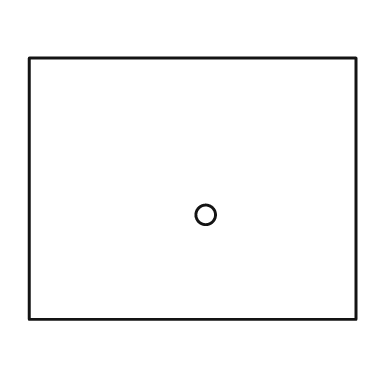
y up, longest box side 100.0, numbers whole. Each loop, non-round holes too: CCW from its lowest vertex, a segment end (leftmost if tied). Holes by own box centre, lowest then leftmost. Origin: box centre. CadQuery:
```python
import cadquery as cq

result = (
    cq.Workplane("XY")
    .moveTo(-50.0, -40.0)
    .lineTo(50.0, -40.0)
    .lineTo(50.0, 40.0)
    .lineTo(-50.0, 40.0)
    .close()
    .moveTo(4.0, -8.0)
    .circle(3.0)
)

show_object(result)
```